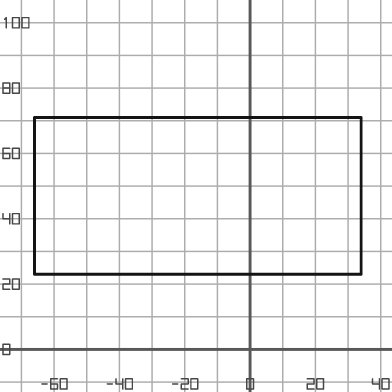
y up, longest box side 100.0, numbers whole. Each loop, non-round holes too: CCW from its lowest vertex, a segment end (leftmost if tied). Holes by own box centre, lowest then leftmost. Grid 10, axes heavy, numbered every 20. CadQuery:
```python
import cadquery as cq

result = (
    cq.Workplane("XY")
    .moveTo(-66.0, 23.0)
    .lineTo(34.0, 23.0)
    .lineTo(34.0, 71.0)
    .lineTo(-66.0, 71.0)
    .close()
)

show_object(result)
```